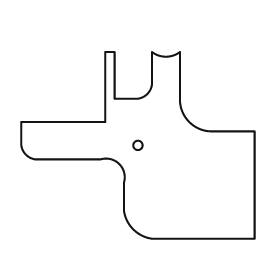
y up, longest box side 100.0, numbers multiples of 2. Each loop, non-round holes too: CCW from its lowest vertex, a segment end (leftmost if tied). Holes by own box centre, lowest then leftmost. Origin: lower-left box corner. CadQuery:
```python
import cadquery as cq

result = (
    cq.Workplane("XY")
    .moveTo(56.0, 0.0)
    .lineTo(100.0, 0.0)
    .lineTo(100.0, 46.0)
    .lineTo(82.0, 46.0)
    .threePointArc((72.0, 50.0), (68.0, 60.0))
    .lineTo(68.0, 80.0)
    .threePointArc((62.0, 78.0), (56.0, 80.0))
    .lineTo(56.0, 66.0)
    .threePointArc((54.0, 62.0), (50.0, 60.0))
    .lineTo(40.0, 60.0)
    .lineTo(40.0, 80.0)
    .lineTo(36.0, 80.0)
    .lineTo(36.0, 50.0)
    .lineTo(0.0, 50.0)
    .lineTo(0.0, 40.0)
    .threePointArc((2.0, 36.0), (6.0, 34.0))
    .lineTo(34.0, 34.0)
    .threePointArc((42.0, 32.0), (44.0, 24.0))
    .lineTo(44.0, 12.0)
    .threePointArc((48.0, 4.0), (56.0, 0.0))
    .close()
    .moveTo(50.0, 40.0)
    .circle(2.0)
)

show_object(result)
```